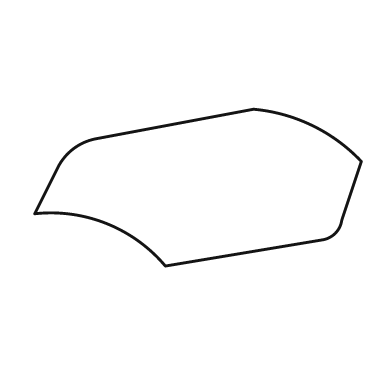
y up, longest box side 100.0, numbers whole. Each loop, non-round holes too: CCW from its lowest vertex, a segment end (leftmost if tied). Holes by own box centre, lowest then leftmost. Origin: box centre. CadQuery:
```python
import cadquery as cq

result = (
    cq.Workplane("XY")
    .moveTo(-10.0, -24.0)
    .lineTo(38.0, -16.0)
    .threePointArc((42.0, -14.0), (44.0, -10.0))
    .lineTo(50.0, 8.0)
    .threePointArc((35.0, 19.0), (17.0, 24.0))
    .lineTo(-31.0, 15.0)
    .threePointArc((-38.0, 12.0), (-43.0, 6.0))
    .lineTo(-50.0, -8.0)
    .threePointArc((-28.0, -11.0), (-10.0, -24.0))
    .close()
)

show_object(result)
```